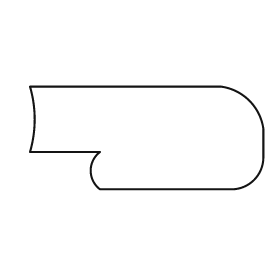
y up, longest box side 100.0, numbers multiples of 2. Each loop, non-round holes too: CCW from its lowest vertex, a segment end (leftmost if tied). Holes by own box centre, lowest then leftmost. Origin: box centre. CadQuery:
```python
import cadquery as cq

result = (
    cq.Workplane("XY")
    .moveTo(-20.0, -22.0)
    .lineTo(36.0, -22.0)
    .threePointArc((46.0, -18.0), (50.0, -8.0))
    .lineTo(50.0, 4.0)
    .threePointArc((44.0, 16.0), (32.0, 22.0))
    .lineTo(-50.0, 22.0)
    .threePointArc((-48.0, 8.0), (-50.0, -6.0))
    .lineTo(-20.0, -6.0)
    .threePointArc((-24.0, -14.0), (-20.0, -22.0))
    .close()
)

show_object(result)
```